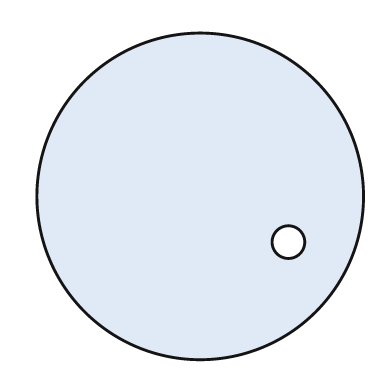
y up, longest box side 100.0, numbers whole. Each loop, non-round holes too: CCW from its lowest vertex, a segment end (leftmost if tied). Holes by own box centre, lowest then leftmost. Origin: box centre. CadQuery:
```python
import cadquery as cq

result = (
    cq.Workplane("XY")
    .moveTo(0.0, 0.0)
    .circle(50.0)
    .moveTo(27.0, -14.0)
    .circle(5.0)
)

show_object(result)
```